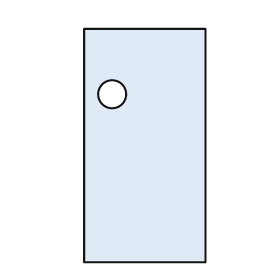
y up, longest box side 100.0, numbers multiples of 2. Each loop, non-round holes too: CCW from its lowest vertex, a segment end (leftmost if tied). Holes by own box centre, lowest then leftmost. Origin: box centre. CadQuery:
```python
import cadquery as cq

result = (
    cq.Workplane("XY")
    .moveTo(-26.0, -50.0)
    .lineTo(26.0, -50.0)
    .lineTo(26.0, 50.0)
    .lineTo(-26.0, 50.0)
    .close()
    .moveTo(-14.0, 22.0)
    .circle(6.0)
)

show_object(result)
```